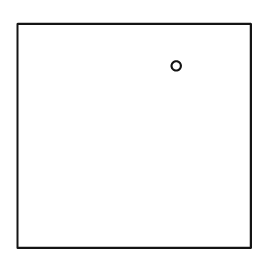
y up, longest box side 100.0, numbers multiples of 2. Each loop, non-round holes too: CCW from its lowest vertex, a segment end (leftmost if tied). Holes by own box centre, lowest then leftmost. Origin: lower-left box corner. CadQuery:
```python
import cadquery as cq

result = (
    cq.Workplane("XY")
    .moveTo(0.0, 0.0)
    .lineTo(100.0, 0.0)
    .lineTo(100.0, 96.0)
    .lineTo(0.0, 96.0)
    .close()
    .moveTo(68.0, 78.0)
    .circle(2.0)
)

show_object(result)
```